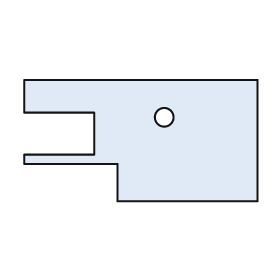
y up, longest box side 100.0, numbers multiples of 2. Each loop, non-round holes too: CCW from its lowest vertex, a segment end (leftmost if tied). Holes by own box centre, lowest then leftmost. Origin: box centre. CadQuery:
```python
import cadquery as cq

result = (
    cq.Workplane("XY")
    .moveTo(-10.0, -26.0)
    .lineTo(50.0, -26.0)
    .lineTo(50.0, 26.0)
    .lineTo(-50.0, 26.0)
    .lineTo(-50.0, 12.0)
    .lineTo(-20.0, 12.0)
    .lineTo(-20.0, -6.0)
    .lineTo(-50.0, -6.0)
    .lineTo(-50.0, -10.0)
    .lineTo(-10.0, -10.0)
    .close()
    .moveTo(10.0, 10.0)
    .circle(4.0)
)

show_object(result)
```